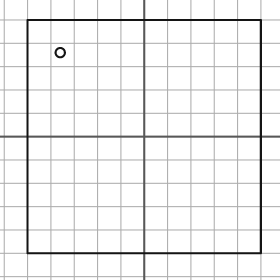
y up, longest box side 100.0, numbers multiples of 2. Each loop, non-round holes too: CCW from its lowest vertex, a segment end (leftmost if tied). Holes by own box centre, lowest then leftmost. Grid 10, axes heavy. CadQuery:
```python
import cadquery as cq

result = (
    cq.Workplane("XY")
    .moveTo(-50.0, -50.0)
    .lineTo(50.0, -50.0)
    .lineTo(50.0, 50.0)
    .lineTo(-50.0, 50.0)
    .close()
    .moveTo(-36.0, 36.0)
    .circle(2.0)
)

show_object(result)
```